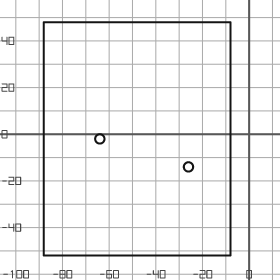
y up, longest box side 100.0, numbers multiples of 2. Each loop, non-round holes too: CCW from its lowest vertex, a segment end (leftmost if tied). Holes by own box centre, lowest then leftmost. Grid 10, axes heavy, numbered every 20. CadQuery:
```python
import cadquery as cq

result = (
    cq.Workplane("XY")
    .moveTo(-88.0, -52.0)
    .lineTo(-8.0, -52.0)
    .lineTo(-8.0, 48.0)
    .lineTo(-88.0, 48.0)
    .close()
    .moveTo(-26.0, -14.0)
    .circle(2.0)
    .moveTo(-64.0, -2.0)
    .circle(2.0)
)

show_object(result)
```